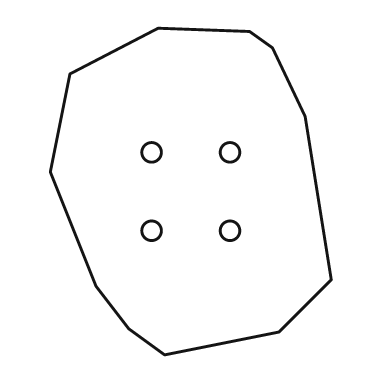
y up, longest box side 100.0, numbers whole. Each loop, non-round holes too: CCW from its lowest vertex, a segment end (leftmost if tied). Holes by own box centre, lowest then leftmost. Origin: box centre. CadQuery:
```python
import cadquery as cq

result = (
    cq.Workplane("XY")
    .moveTo(-8.0, -50.0)
    .lineTo(27.0, -43.0)
    .lineTo(43.0, -27.0)
    .lineTo(35.0, 23.0)
    .lineTo(25.0, 44.0)
    .lineTo(18.0, 49.0)
    .lineTo(-10.0, 50.0)
    .lineTo(-37.0, 36.0)
    .lineTo(-43.0, 6.0)
    .lineTo(-29.0, -29.0)
    .lineTo(-19.0, -42.0)
    .close()
    .moveTo(-12.0, -12.0)
    .circle(3.0)
    .moveTo(12.0, -12.0)
    .circle(3.0)
    .moveTo(-12.0, 12.0)
    .circle(3.0)
    .moveTo(12.0, 12.0)
    .circle(3.0)
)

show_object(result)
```